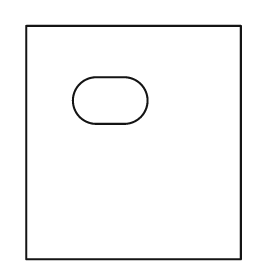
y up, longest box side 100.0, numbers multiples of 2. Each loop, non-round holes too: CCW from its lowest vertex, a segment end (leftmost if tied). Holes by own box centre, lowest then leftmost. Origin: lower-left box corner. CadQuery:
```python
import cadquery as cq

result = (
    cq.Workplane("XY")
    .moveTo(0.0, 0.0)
    .lineTo(92.0, 0.0)
    .lineTo(92.0, 100.0)
    .lineTo(0.0, 100.0)
    .close()
    .moveTo(30.0, 58.0)
    .lineTo(42.0, 58.0)
    .threePointArc((52.0, 68.0), (42.0, 78.0))
    .lineTo(30.0, 78.0)
    .threePointArc((20.0, 68.0), (30.0, 58.0))
    .close()
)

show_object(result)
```